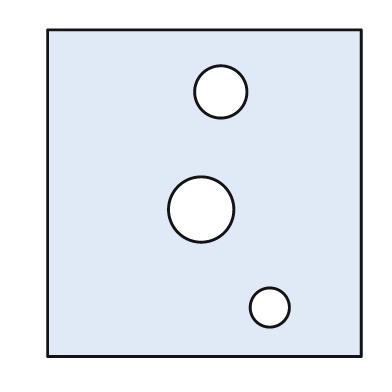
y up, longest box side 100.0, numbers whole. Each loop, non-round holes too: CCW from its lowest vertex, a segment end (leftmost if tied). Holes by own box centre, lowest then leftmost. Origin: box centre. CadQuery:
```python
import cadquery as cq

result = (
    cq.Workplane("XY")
    .moveTo(-48.0, -50.0)
    .lineTo(48.0, -50.0)
    .lineTo(48.0, 50.0)
    .lineTo(-48.0, 50.0)
    .close()
    .moveTo(20.0, -35.0)
    .circle(6.0)
    .moveTo(-1.0, -5.0)
    .circle(10.0)
    .moveTo(5.0, 31.0)
    .circle(8.0)
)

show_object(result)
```